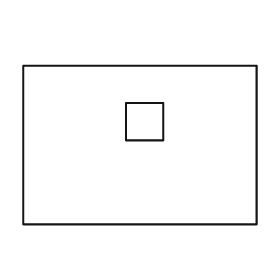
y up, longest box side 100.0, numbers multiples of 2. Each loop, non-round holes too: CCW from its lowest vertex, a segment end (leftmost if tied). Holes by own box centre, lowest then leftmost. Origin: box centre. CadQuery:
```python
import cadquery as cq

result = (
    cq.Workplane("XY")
    .moveTo(-50.0, -34.0)
    .lineTo(50.0, -34.0)
    .lineTo(50.0, 34.0)
    .lineTo(-50.0, 34.0)
    .close()
    .moveTo(-6.0, 2.0)
    .lineTo(10.0, 2.0)
    .lineTo(10.0, 18.0)
    .lineTo(-6.0, 18.0)
    .close()
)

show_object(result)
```